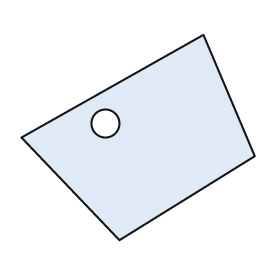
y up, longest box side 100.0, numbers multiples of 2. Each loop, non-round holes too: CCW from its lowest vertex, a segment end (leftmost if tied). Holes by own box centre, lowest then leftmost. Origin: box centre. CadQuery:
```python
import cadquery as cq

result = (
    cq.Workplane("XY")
    .moveTo(-8.0, -44.0)
    .lineTo(50.0, -8.0)
    .lineTo(28.0, 44.0)
    .lineTo(-50.0, 0.0)
    .close()
    .moveTo(-14.0, 6.0)
    .circle(6.0)
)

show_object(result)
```